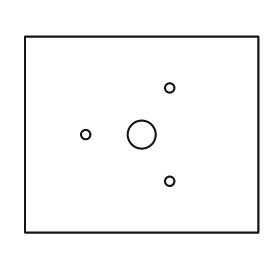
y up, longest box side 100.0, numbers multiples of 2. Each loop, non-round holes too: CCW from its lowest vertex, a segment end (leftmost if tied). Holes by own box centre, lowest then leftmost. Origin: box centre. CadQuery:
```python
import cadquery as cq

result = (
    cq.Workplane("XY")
    .moveTo(-50.0, -42.0)
    .lineTo(50.0, -42.0)
    .lineTo(50.0, 42.0)
    .lineTo(-50.0, 42.0)
    .close()
    .moveTo(12.0, -20.0)
    .circle(2.0)
    .moveTo(-24.0, 0.0)
    .circle(2.0)
    .moveTo(0.0, 0.0)
    .circle(6.0)
    .moveTo(12.0, 20.0)
    .circle(2.0)
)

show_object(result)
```